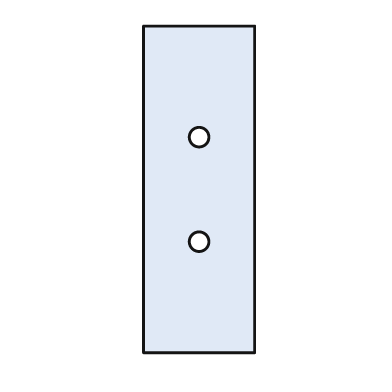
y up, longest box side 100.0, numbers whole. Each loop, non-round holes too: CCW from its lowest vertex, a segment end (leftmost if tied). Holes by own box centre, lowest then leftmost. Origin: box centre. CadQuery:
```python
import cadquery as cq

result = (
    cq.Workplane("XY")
    .moveTo(-17.0, -50.0)
    .lineTo(17.0, -50.0)
    .lineTo(17.0, 50.0)
    .lineTo(-17.0, 50.0)
    .close()
    .moveTo(0.0, -16.0)
    .circle(3.0)
    .moveTo(0.0, 16.0)
    .circle(3.0)
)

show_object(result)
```